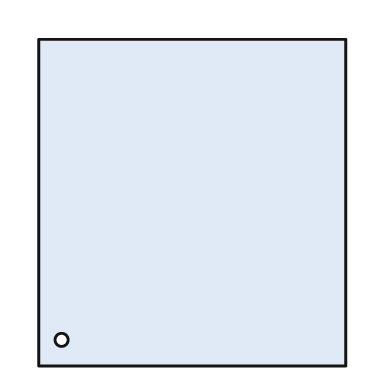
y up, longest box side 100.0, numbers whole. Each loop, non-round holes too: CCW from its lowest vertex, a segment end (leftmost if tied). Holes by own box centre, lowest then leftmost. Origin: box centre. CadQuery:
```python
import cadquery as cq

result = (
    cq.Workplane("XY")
    .moveTo(-47.0, -50.0)
    .lineTo(47.0, -50.0)
    .lineTo(47.0, 50.0)
    .lineTo(-47.0, 50.0)
    .close()
    .moveTo(-40.0, -42.0)
    .circle(2.0)
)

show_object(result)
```